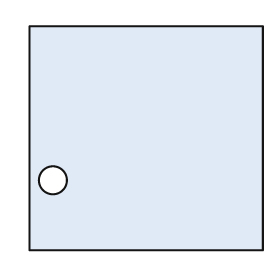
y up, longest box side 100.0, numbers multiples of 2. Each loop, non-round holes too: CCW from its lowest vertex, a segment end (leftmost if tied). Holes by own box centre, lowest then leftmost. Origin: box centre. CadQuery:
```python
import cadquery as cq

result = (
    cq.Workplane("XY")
    .moveTo(-50.0, -48.0)
    .lineTo(50.0, -48.0)
    .lineTo(50.0, 48.0)
    .lineTo(-50.0, 48.0)
    .close()
    .moveTo(-40.0, -18.0)
    .circle(6.0)
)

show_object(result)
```